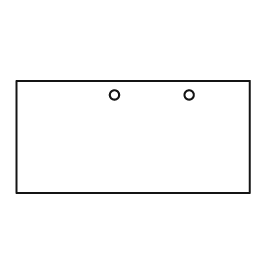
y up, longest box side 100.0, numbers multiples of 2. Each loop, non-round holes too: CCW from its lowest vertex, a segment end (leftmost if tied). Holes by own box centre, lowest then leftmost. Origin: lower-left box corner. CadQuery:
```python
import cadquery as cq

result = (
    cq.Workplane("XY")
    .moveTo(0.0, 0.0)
    .lineTo(100.0, 0.0)
    .lineTo(100.0, 48.0)
    .lineTo(0.0, 48.0)
    .close()
    .moveTo(42.0, 42.0)
    .circle(2.0)
    .moveTo(74.0, 42.0)
    .circle(2.0)
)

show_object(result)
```